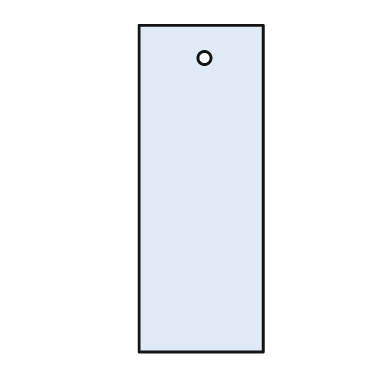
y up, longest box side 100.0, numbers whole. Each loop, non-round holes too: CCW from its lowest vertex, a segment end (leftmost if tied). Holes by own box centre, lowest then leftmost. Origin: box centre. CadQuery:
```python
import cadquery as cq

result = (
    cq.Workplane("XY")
    .moveTo(-19.0, -50.0)
    .lineTo(19.0, -50.0)
    .lineTo(19.0, 50.0)
    .lineTo(-19.0, 50.0)
    .close()
    .moveTo(1.0, 40.0)
    .circle(2.0)
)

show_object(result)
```